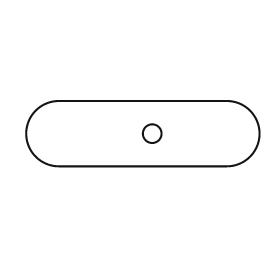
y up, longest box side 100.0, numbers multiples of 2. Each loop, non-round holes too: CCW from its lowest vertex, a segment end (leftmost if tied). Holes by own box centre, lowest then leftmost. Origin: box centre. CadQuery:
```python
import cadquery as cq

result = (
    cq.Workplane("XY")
    .moveTo(-36.0, -14.0)
    .lineTo(36.0, -14.0)
    .threePointArc((50.0, 0.0), (36.0, 14.0))
    .lineTo(-36.0, 14.0)
    .threePointArc((-50.0, 0.0), (-36.0, -14.0))
    .close()
    .moveTo(4.0, 0.0)
    .circle(4.0)
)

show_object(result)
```